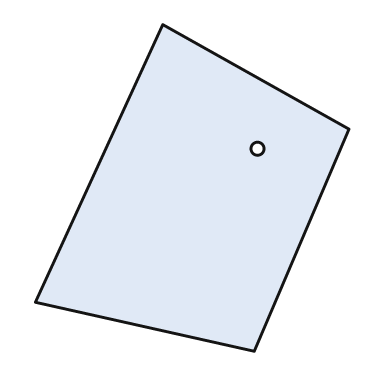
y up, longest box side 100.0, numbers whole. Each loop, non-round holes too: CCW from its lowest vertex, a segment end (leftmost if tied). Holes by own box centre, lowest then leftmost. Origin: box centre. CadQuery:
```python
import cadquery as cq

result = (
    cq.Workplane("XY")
    .moveTo(19.0, -50.0)
    .lineTo(48.0, 18.0)
    .lineTo(-9.0, 50.0)
    .lineTo(-48.0, -35.0)
    .close()
    .moveTo(20.0, 12.0)
    .circle(2.0)
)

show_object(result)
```